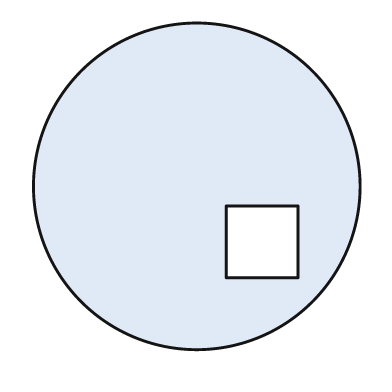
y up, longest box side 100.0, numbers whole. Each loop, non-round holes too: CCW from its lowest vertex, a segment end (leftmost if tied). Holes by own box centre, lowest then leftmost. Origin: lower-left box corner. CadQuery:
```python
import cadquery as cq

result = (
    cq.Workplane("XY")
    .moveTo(50.0, 50.0)
    .circle(50.0)
    .moveTo(59.0, 22.0)
    .lineTo(81.0, 22.0)
    .lineTo(81.0, 44.0)
    .lineTo(59.0, 44.0)
    .close()
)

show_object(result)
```